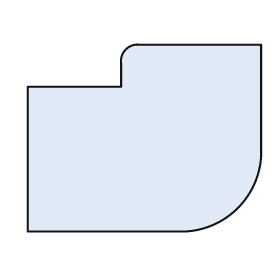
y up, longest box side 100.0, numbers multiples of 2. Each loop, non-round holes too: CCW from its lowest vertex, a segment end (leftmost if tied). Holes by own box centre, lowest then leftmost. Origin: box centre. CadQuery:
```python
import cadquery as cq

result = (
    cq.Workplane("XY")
    .moveTo(-50.0, -40.0)
    .lineTo(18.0, -40.0)
    .threePointArc((40.0, -30.0), (50.0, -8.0))
    .lineTo(50.0, 40.0)
    .lineTo(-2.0, 40.0)
    .threePointArc((-8.0, 38.0), (-10.0, 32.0))
    .lineTo(-10.0, 22.0)
    .lineTo(-50.0, 22.0)
    .close()
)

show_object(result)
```